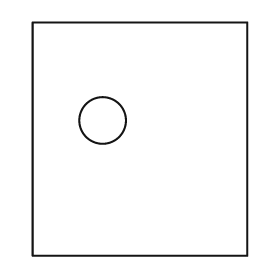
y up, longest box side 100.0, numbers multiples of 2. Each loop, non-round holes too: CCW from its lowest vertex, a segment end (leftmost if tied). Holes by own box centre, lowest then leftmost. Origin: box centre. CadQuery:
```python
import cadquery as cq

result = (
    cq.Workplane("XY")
    .moveTo(-46.0, -50.0)
    .lineTo(46.0, -50.0)
    .lineTo(46.0, 50.0)
    .lineTo(-46.0, 50.0)
    .close()
    .moveTo(-16.0, 8.0)
    .circle(10.0)
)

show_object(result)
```